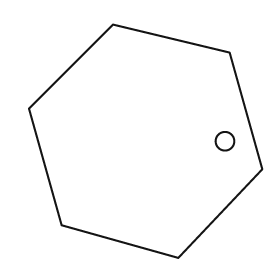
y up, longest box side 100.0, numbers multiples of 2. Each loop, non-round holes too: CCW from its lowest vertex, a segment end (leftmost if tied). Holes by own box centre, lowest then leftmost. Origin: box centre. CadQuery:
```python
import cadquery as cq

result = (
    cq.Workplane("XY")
    .moveTo(14.0, -50.0)
    .lineTo(50.0, -12.0)
    .lineTo(36.0, 38.0)
    .lineTo(-14.0, 50.0)
    .lineTo(-50.0, 14.0)
    .lineTo(-36.0, -36.0)
    .close()
    .moveTo(34.0, 0.0)
    .circle(4.0)
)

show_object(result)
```